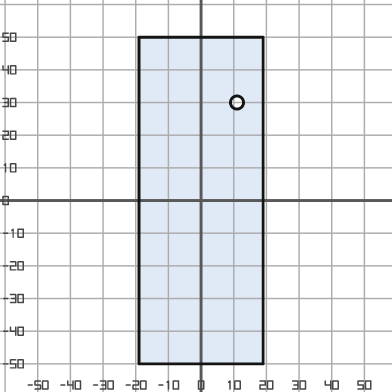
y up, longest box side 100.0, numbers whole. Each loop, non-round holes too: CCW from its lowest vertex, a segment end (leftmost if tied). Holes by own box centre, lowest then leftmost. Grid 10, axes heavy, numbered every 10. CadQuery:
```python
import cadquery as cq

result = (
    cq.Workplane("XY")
    .moveTo(-19.0, -50.0)
    .lineTo(19.0, -50.0)
    .lineTo(19.0, 50.0)
    .lineTo(-19.0, 50.0)
    .close()
    .moveTo(11.0, 30.0)
    .circle(2.0)
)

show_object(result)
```